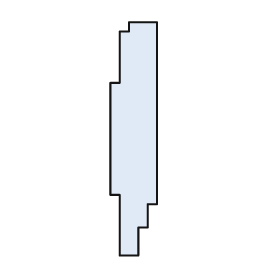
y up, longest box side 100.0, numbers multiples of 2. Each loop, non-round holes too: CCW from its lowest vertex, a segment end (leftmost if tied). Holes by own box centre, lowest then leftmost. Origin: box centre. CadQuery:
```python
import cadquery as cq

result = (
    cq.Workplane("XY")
    .moveTo(-6.0, -50.0)
    .lineTo(2.0, -50.0)
    .lineTo(2.0, -38.0)
    .lineTo(6.0, -38.0)
    .lineTo(6.0, -28.0)
    .lineTo(10.0, -28.0)
    .lineTo(10.0, 50.0)
    .lineTo(-2.0, 50.0)
    .lineTo(-2.0, 46.0)
    .lineTo(-6.0, 46.0)
    .lineTo(-6.0, 24.0)
    .lineTo(-10.0, 24.0)
    .lineTo(-10.0, -24.0)
    .lineTo(-6.0, -24.0)
    .close()
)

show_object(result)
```